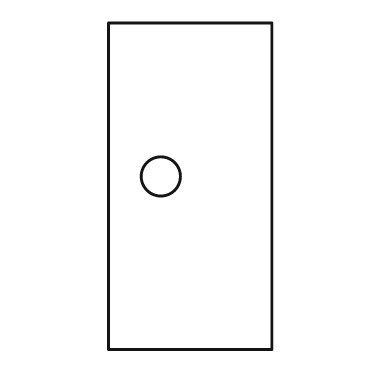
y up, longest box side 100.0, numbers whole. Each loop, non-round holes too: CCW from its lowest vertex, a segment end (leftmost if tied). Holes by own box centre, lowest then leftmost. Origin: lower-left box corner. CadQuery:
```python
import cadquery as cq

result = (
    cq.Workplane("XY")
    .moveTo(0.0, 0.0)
    .lineTo(50.0, 0.0)
    .lineTo(50.0, 100.0)
    .lineTo(0.0, 100.0)
    .close()
    .moveTo(16.0, 53.0)
    .circle(6.0)
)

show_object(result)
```